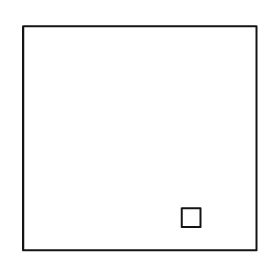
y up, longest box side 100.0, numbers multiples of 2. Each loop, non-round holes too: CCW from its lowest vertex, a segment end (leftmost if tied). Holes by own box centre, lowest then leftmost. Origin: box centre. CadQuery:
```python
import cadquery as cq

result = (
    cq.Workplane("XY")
    .moveTo(-50.0, -48.0)
    .lineTo(50.0, -48.0)
    .lineTo(50.0, 48.0)
    .lineTo(-50.0, 48.0)
    .close()
    .moveTo(18.0, -38.0)
    .lineTo(26.0, -38.0)
    .lineTo(26.0, -30.0)
    .lineTo(18.0, -30.0)
    .close()
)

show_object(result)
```